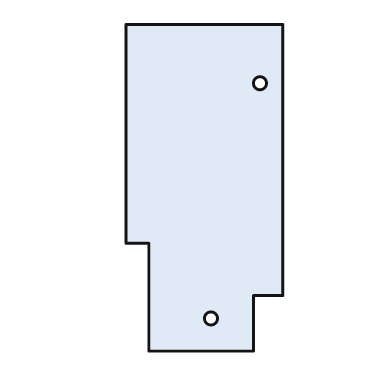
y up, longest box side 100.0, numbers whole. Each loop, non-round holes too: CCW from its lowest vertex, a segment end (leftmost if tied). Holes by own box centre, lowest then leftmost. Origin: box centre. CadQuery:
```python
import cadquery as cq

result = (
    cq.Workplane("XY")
    .moveTo(-17.0, -50.0)
    .lineTo(15.0, -50.0)
    .lineTo(15.0, -33.0)
    .lineTo(24.0, -33.0)
    .lineTo(24.0, 50.0)
    .lineTo(-24.0, 50.0)
    .lineTo(-24.0, -17.0)
    .lineTo(-17.0, -17.0)
    .close()
    .moveTo(2.0, -40.0)
    .circle(2.0)
    .moveTo(17.0, 32.0)
    .circle(2.0)
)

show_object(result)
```